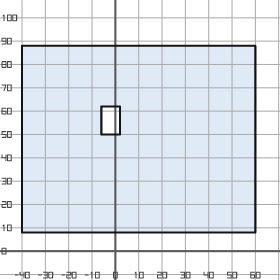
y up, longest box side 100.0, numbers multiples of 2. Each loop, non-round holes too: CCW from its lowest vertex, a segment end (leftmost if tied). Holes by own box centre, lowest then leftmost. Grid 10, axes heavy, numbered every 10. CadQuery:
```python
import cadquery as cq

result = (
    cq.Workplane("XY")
    .moveTo(-40.0, 8.0)
    .lineTo(60.0, 8.0)
    .lineTo(60.0, 88.0)
    .lineTo(-40.0, 88.0)
    .close()
    .moveTo(-6.0, 50.0)
    .lineTo(2.0, 50.0)
    .lineTo(2.0, 62.0)
    .lineTo(-6.0, 62.0)
    .close()
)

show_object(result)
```